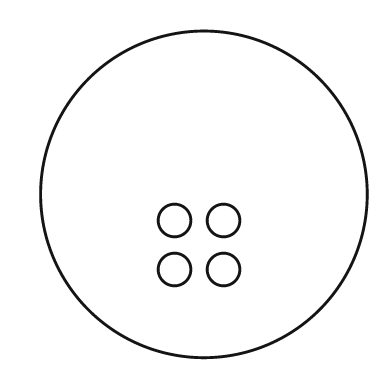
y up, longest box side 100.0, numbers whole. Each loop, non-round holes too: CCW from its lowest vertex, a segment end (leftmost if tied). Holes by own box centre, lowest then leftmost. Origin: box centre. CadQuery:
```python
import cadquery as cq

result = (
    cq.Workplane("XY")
    .moveTo(0.0, 0.0)
    .circle(50.0)
    .moveTo(-9.0, -23.0)
    .circle(5.0)
    .moveTo(6.0, -23.0)
    .circle(5.0)
    .moveTo(-9.0, -8.0)
    .circle(5.0)
    .moveTo(6.0, -8.0)
    .circle(5.0)
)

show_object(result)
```